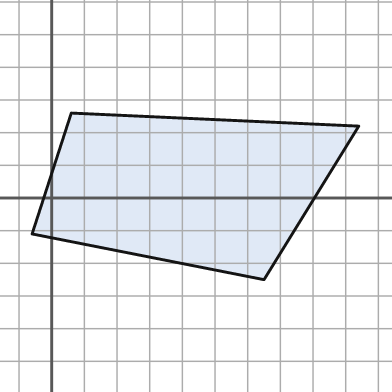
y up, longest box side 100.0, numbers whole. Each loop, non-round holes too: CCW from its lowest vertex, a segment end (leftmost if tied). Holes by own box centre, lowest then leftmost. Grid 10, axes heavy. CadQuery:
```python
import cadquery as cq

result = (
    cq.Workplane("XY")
    .moveTo(65.0, -25.0)
    .lineTo(94.0, 22.0)
    .lineTo(6.0, 26.0)
    .lineTo(-6.0, -11.0)
    .close()
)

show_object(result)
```